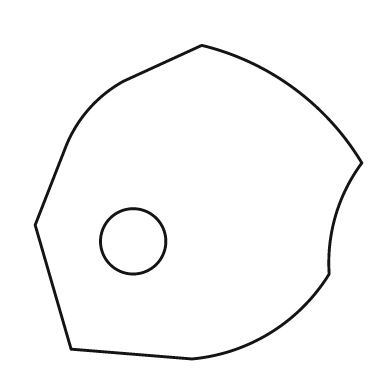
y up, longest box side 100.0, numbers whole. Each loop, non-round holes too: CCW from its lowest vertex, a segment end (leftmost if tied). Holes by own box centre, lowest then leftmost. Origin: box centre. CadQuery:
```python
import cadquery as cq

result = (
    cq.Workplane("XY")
    .moveTo(-2.0, -48.0)
    .threePointArc((22.0, -40.0), (40.0, -22.0))
    .threePointArc((42.0, -4.0), (50.0, 12.0))
    .threePointArc((29.0, 35.0), (1.0, 48.0))
    .lineTo(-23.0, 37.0)
    .threePointArc((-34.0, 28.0), (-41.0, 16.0))
    .lineTo(-50.0, -7.0)
    .lineTo(-39.0, -45.0)
    .close()
    .moveTo(-20.0, -12.0)
    .circle(10.0)
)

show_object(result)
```